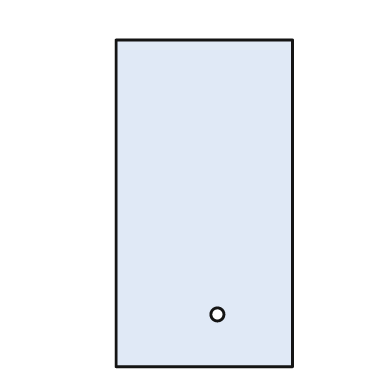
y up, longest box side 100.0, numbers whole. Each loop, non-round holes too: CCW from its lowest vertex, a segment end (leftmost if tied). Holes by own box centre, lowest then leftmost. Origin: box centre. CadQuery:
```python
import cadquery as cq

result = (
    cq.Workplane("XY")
    .moveTo(-27.0, -50.0)
    .lineTo(27.0, -50.0)
    .lineTo(27.0, 50.0)
    .lineTo(-27.0, 50.0)
    .close()
    .moveTo(4.0, -34.0)
    .circle(2.0)
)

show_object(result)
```